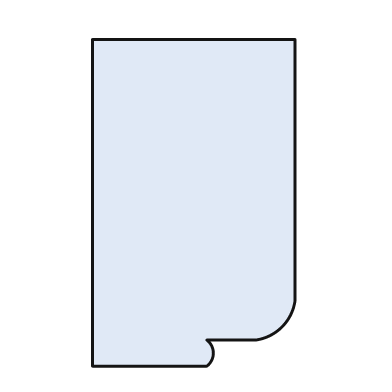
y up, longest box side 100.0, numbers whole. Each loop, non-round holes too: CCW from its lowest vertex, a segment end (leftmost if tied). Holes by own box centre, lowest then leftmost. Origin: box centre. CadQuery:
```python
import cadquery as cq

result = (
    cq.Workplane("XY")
    .moveTo(-31.0, -50.0)
    .lineTo(4.0, -50.0)
    .threePointArc((6.0, -46.0), (4.0, -42.0))
    .lineTo(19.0, -42.0)
    .threePointArc((27.0, -38.0), (31.0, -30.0))
    .lineTo(31.0, 50.0)
    .lineTo(-31.0, 50.0)
    .close()
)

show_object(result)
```